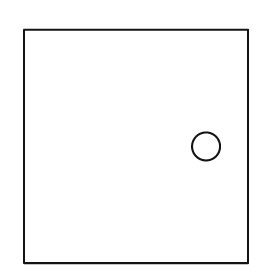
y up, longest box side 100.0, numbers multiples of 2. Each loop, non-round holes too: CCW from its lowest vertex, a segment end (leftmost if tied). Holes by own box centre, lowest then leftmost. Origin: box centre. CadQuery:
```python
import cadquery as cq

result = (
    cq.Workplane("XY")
    .moveTo(-48.0, -50.0)
    .lineTo(48.0, -50.0)
    .lineTo(48.0, 50.0)
    .lineTo(-48.0, 50.0)
    .close()
    .moveTo(30.0, 0.0)
    .circle(6.0)
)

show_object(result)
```